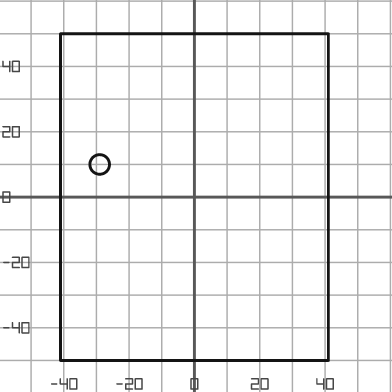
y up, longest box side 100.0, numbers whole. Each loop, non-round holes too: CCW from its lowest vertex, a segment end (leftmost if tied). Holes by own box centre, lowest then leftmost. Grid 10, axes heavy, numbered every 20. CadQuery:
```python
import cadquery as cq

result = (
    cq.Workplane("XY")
    .moveTo(-41.0, -50.0)
    .lineTo(41.0, -50.0)
    .lineTo(41.0, 50.0)
    .lineTo(-41.0, 50.0)
    .close()
    .moveTo(-29.0, 10.0)
    .circle(3.0)
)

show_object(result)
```